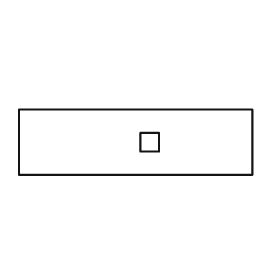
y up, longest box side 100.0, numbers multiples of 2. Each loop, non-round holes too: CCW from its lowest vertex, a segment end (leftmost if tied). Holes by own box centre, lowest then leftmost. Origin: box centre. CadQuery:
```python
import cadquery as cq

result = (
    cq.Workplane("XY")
    .moveTo(-50.0, -14.0)
    .lineTo(50.0, -14.0)
    .lineTo(50.0, 14.0)
    .lineTo(-50.0, 14.0)
    .close()
    .moveTo(2.0, -4.0)
    .lineTo(10.0, -4.0)
    .lineTo(10.0, 4.0)
    .lineTo(2.0, 4.0)
    .close()
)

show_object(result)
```